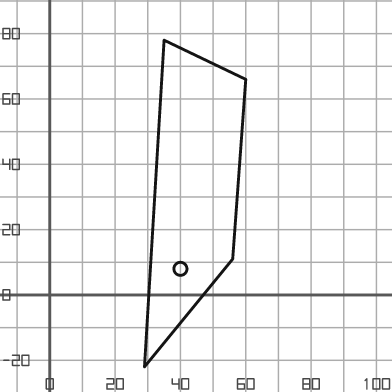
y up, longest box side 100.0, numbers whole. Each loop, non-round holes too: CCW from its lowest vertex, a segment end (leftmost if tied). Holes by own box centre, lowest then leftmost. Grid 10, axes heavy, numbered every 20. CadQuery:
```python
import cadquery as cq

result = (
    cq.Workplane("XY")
    .moveTo(29.0, -22.0)
    .lineTo(56.0, 11.0)
    .lineTo(60.0, 66.0)
    .lineTo(35.0, 78.0)
    .close()
    .moveTo(40.0, 8.0)
    .circle(2.0)
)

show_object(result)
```